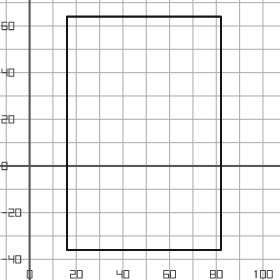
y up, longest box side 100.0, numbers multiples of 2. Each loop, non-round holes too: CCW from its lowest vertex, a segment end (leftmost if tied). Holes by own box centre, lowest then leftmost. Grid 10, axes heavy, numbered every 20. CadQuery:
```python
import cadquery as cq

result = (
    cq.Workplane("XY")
    .moveTo(16.0, -36.0)
    .lineTo(82.0, -36.0)
    .lineTo(82.0, 64.0)
    .lineTo(16.0, 64.0)
    .close()
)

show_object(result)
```